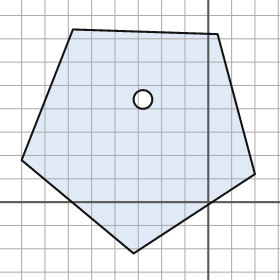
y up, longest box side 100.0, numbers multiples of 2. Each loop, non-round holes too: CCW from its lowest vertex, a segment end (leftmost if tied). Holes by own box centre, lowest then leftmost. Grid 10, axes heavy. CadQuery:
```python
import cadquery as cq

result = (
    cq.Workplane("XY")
    .moveTo(-32.0, -22.0)
    .lineTo(20.0, 12.0)
    .lineTo(4.0, 72.0)
    .lineTo(-58.0, 74.0)
    .lineTo(-80.0, 18.0)
    .close()
    .moveTo(-28.0, 44.0)
    .circle(4.0)
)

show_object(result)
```